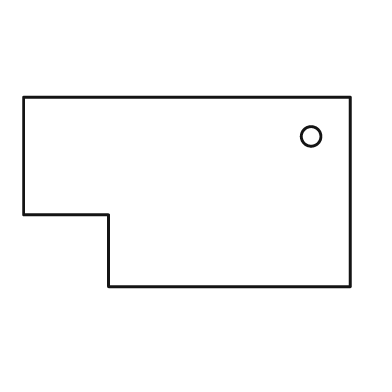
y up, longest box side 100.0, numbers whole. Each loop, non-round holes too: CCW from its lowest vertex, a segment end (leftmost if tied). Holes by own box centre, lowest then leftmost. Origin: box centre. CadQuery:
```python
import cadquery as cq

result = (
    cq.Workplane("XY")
    .moveTo(-24.0, -29.0)
    .lineTo(50.0, -29.0)
    .lineTo(50.0, 29.0)
    .lineTo(-50.0, 29.0)
    .lineTo(-50.0, -7.0)
    .lineTo(-24.0, -7.0)
    .close()
    .moveTo(38.0, 17.0)
    .circle(3.0)
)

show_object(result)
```